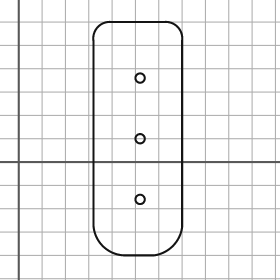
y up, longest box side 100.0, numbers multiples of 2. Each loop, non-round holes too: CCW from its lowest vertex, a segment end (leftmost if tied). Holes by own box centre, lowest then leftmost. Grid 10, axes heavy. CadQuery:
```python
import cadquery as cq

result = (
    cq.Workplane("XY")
    .moveTo(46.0, -40.0)
    .lineTo(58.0, -40.0)
    .threePointArc((66.0, -36.0), (70.0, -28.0))
    .lineTo(70.0, 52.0)
    .threePointArc((68.0, 58.0), (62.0, 60.0))
    .lineTo(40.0, 60.0)
    .threePointArc((34.0, 58.0), (32.0, 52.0))
    .lineTo(32.0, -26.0)
    .threePointArc((36.0, -36.0), (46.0, -40.0))
    .close()
    .moveTo(52.0, -16.0)
    .circle(2.0)
    .moveTo(52.0, 10.0)
    .circle(2.0)
    .moveTo(52.0, 36.0)
    .circle(2.0)
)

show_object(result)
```